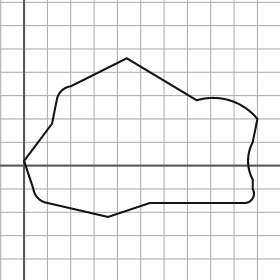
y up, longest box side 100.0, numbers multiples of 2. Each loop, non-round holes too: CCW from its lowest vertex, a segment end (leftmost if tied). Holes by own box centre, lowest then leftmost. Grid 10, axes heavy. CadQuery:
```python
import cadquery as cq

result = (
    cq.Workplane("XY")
    .moveTo(36.0, -22.0)
    .lineTo(54.0, -16.0)
    .lineTo(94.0, -16.0)
    .threePointArc((98.0, -14.0), (98.0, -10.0))
    .lineTo(98.0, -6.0)
    .threePointArc((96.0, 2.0), (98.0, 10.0))
    .lineTo(100.0, 20.0)
    .threePointArc((88.0, 28.0), (74.0, 28.0))
    .lineTo(44.0, 46.0)
    .lineTo(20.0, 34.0)
    .threePointArc((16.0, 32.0), (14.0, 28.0))
    .lineTo(12.0, 18.0)
    .lineTo(0.0, 2.0)
    .lineTo(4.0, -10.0)
    .threePointArc((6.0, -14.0), (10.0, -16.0))
    .close()
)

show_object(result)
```